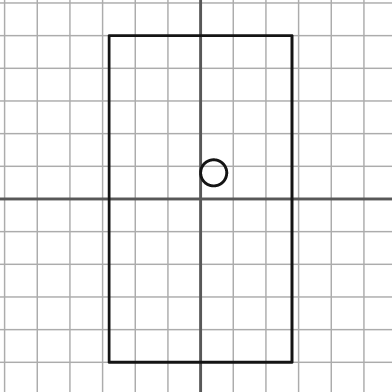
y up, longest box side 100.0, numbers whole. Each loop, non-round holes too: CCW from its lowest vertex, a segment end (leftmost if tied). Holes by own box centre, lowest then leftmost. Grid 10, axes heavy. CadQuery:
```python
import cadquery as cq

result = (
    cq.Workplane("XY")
    .moveTo(-28.0, -50.0)
    .lineTo(28.0, -50.0)
    .lineTo(28.0, 50.0)
    .lineTo(-28.0, 50.0)
    .close()
    .moveTo(4.0, 8.0)
    .circle(4.0)
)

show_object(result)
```